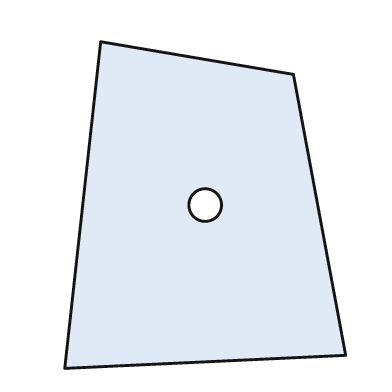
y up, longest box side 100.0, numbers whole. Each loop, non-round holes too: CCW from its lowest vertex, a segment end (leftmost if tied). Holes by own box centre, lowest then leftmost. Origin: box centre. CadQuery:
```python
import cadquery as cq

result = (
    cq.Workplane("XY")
    .moveTo(-43.0, -50.0)
    .lineTo(43.0, -46.0)
    .lineTo(27.0, 40.0)
    .lineTo(-32.0, 50.0)
    .close()
    .moveTo(0.0, 0.0)
    .circle(5.0)
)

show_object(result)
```